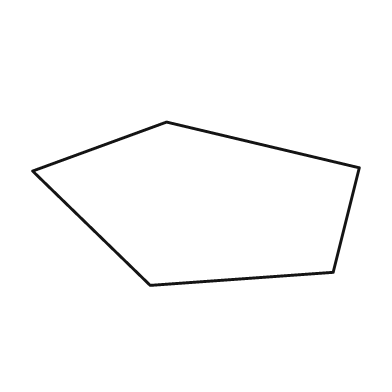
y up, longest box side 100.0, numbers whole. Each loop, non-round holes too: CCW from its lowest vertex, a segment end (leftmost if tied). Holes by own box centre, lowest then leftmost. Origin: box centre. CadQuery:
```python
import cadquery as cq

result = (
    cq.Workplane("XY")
    .moveTo(-14.0, -25.0)
    .lineTo(42.0, -21.0)
    .lineTo(50.0, 11.0)
    .lineTo(-9.0, 25.0)
    .lineTo(-50.0, 10.0)
    .close()
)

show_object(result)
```